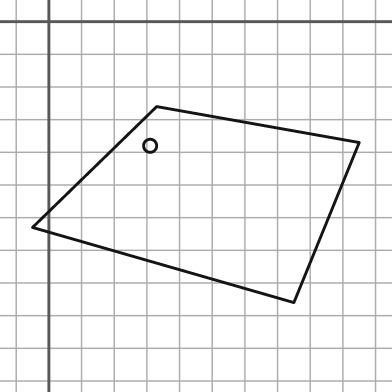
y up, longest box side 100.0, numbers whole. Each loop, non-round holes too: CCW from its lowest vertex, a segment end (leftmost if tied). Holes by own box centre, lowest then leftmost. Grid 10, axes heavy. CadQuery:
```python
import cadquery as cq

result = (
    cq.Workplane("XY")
    .moveTo(75.0, -86.0)
    .lineTo(95.0, -37.0)
    .lineTo(33.0, -26.0)
    .lineTo(-5.0, -63.0)
    .close()
    .moveTo(31.0, -38.0)
    .circle(2.0)
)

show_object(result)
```